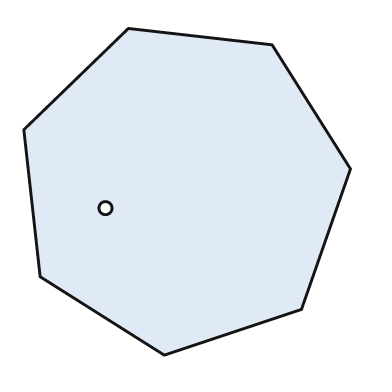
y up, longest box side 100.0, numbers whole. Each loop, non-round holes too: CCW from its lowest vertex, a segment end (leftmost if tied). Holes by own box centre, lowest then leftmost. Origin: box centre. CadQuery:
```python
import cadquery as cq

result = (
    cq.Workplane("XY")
    .moveTo(-7.0, -50.0)
    .lineTo(35.0, -36.0)
    .lineTo(50.0, 7.0)
    .lineTo(26.0, 45.0)
    .lineTo(-18.0, 50.0)
    .lineTo(-50.0, 19.0)
    .lineTo(-45.0, -26.0)
    .close()
    .moveTo(-25.0, -5.0)
    .circle(2.0)
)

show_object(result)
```